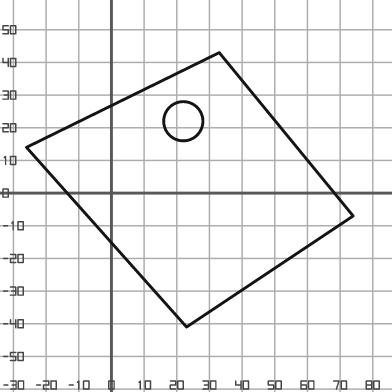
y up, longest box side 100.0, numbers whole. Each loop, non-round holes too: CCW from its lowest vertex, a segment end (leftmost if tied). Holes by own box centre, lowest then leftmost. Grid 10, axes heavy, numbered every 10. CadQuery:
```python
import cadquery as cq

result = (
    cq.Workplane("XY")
    .moveTo(23.0, -41.0)
    .lineTo(74.0, -7.0)
    .lineTo(33.0, 43.0)
    .lineTo(-26.0, 14.0)
    .close()
    .moveTo(22.0, 22.0)
    .circle(6.0)
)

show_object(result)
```